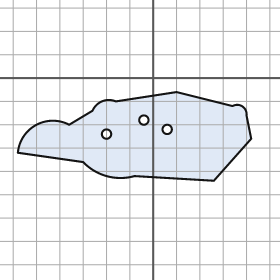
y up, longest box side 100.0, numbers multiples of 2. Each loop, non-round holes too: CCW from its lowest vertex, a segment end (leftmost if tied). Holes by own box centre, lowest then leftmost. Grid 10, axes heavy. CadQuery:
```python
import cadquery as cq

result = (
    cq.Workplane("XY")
    .moveTo(26.0, -44.0)
    .lineTo(42.0, -26.0)
    .lineTo(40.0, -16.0)
    .threePointArc((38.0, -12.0), (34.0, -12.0))
    .lineTo(10.0, -6.0)
    .lineTo(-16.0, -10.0)
    .threePointArc((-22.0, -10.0), (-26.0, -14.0))
    .lineTo(-36.0, -20.0)
    .threePointArc((-50.0, -20.0), (-58.0, -32.0))
    .lineTo(-30.0, -36.0)
    .threePointArc((-20.0, -42.0), (-8.0, -42.0))
    .close()
    .moveTo(-20.0, -24.0)
    .circle(2.0)
    .moveTo(6.0, -22.0)
    .circle(2.0)
    .moveTo(-4.0, -18.0)
    .circle(2.0)
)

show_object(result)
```